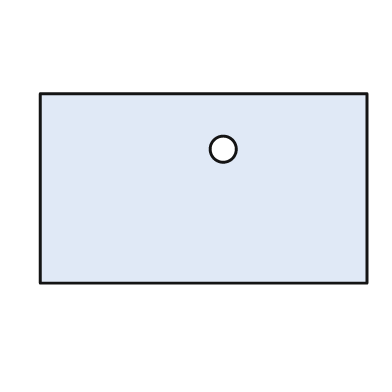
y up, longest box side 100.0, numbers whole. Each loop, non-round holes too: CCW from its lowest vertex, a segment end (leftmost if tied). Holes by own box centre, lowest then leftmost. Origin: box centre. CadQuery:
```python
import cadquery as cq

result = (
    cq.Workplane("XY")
    .moveTo(-50.0, -29.0)
    .lineTo(50.0, -29.0)
    .lineTo(50.0, 29.0)
    .lineTo(-50.0, 29.0)
    .close()
    .moveTo(6.0, 12.0)
    .circle(4.0)
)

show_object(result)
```